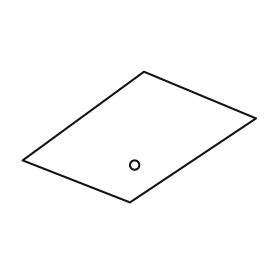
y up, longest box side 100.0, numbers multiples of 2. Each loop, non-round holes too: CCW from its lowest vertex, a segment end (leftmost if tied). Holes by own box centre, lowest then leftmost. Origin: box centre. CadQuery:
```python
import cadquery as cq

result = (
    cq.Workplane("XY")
    .moveTo(-4.0, -28.0)
    .lineTo(50.0, 8.0)
    .lineTo(2.0, 28.0)
    .lineTo(-50.0, -10.0)
    .close()
    .moveTo(-2.0, -12.0)
    .circle(2.0)
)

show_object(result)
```